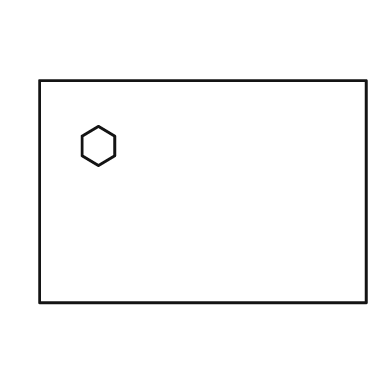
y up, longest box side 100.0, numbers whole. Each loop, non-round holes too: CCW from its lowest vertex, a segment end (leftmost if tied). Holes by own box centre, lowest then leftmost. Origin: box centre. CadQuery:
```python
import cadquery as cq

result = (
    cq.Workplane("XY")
    .moveTo(-50.0, -34.0)
    .lineTo(50.0, -34.0)
    .lineTo(50.0, 34.0)
    .lineTo(-50.0, 34.0)
    .close()
    .moveTo(-32.0, 8.0)
    .lineTo(-27.0, 11.0)
    .lineTo(-27.0, 17.0)
    .lineTo(-32.0, 20.0)
    .lineTo(-37.0, 17.0)
    .lineTo(-37.0, 11.0)
    .close()
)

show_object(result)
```